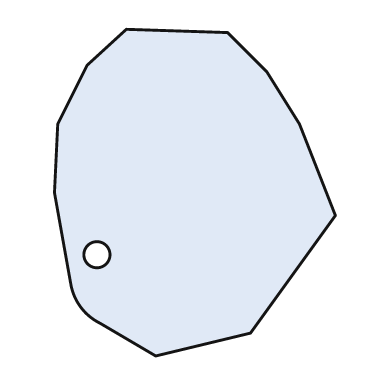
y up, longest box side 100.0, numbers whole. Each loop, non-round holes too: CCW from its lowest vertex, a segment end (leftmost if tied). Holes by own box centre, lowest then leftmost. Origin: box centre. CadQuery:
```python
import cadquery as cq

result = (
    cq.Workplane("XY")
    .moveTo(-12.0, -50.0)
    .lineTo(17.0, -43.0)
    .lineTo(43.0, -7.0)
    .lineTo(32.0, 21.0)
    .lineTo(22.0, 37.0)
    .lineTo(10.0, 49.0)
    .lineTo(-21.0, 50.0)
    .lineTo(-33.0, 39.0)
    .lineTo(-42.0, 21.0)
    .lineTo(-43.0, 0.0)
    .lineTo(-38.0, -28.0)
    .threePointArc((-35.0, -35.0), (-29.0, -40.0))
    .close()
    .moveTo(-30.0, -19.0)
    .circle(4.0)
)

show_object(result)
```